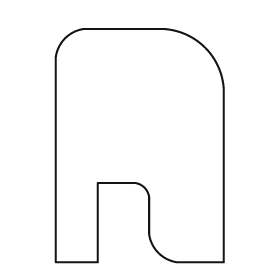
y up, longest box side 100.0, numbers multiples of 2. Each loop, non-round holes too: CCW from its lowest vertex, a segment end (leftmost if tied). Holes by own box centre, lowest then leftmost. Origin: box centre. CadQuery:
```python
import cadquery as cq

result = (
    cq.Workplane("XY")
    .moveTo(-36.0, -50.0)
    .lineTo(-18.0, -50.0)
    .lineTo(-18.0, -16.0)
    .lineTo(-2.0, -16.0)
    .threePointArc((2.0, -18.0), (4.0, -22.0))
    .lineTo(4.0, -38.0)
    .threePointArc((8.0, -46.0), (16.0, -50.0))
    .lineTo(36.0, -50.0)
    .lineTo(36.0, 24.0)
    .threePointArc((28.0, 42.0), (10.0, 50.0))
    .lineTo(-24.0, 50.0)
    .threePointArc((-32.0, 46.0), (-36.0, 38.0))
    .close()
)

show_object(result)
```